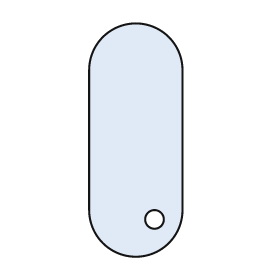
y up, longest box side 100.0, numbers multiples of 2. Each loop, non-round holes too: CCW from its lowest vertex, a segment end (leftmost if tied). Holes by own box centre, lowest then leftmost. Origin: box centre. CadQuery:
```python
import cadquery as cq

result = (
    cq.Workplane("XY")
    .moveTo(-20.0, -30.0)
    .threePointArc((0.0, -50.0), (20.0, -30.0))
    .lineTo(20.0, 30.0)
    .threePointArc((0.0, 50.0), (-20.0, 30.0))
    .close()
    .moveTo(8.0, -34.0)
    .circle(4.0)
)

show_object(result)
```